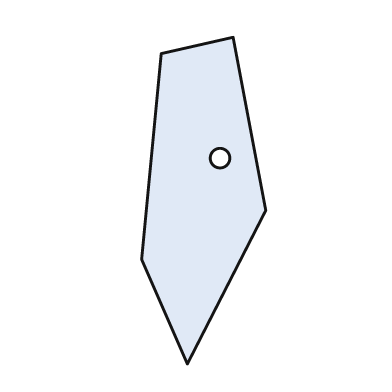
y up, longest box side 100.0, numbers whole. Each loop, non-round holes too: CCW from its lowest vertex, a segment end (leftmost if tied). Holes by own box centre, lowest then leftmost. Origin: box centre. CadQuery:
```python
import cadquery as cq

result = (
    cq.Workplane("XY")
    .moveTo(-5.0, -50.0)
    .lineTo(19.0, -3.0)
    .lineTo(9.0, 50.0)
    .lineTo(-13.0, 45.0)
    .lineTo(-19.0, -18.0)
    .close()
    .moveTo(5.0, 13.0)
    .circle(3.0)
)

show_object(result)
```